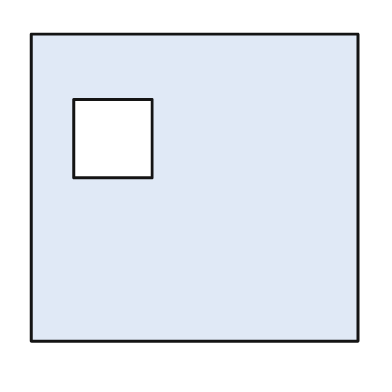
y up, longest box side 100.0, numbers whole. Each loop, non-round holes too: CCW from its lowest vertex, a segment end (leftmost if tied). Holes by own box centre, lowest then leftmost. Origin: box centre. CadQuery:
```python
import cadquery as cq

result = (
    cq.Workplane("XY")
    .moveTo(-50.0, -47.0)
    .lineTo(50.0, -47.0)
    .lineTo(50.0, 47.0)
    .lineTo(-50.0, 47.0)
    .close()
    .moveTo(-37.0, 3.0)
    .lineTo(-13.0, 3.0)
    .lineTo(-13.0, 27.0)
    .lineTo(-37.0, 27.0)
    .close()
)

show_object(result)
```